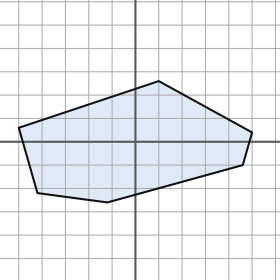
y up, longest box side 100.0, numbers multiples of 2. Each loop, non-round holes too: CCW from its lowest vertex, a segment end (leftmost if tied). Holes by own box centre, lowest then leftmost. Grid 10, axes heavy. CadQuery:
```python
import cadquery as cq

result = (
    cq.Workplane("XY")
    .moveTo(-12.0, -26.0)
    .lineTo(46.0, -10.0)
    .lineTo(50.0, 4.0)
    .lineTo(10.0, 26.0)
    .lineTo(-50.0, 6.0)
    .lineTo(-42.0, -22.0)
    .close()
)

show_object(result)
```